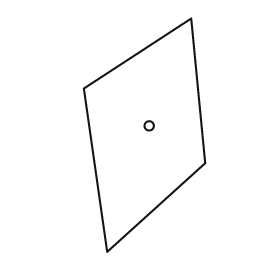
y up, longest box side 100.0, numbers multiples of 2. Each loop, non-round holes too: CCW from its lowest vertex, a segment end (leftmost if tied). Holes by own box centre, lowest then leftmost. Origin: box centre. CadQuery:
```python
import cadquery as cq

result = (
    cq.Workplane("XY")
    .moveTo(-16.0, -50.0)
    .lineTo(26.0, -12.0)
    .lineTo(20.0, 50.0)
    .lineTo(-26.0, 20.0)
    .close()
    .moveTo(2.0, 4.0)
    .circle(2.0)
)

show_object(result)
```